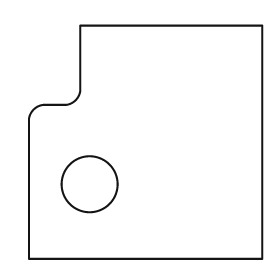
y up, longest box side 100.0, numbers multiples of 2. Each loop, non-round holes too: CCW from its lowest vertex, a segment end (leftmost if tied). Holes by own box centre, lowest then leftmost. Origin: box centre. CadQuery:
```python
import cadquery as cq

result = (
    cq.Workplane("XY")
    .moveTo(-50.0, -50.0)
    .lineTo(50.0, -50.0)
    .lineTo(50.0, 50.0)
    .lineTo(-28.0, 50.0)
    .lineTo(-28.0, 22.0)
    .threePointArc((-30.0, 18.0), (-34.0, 16.0))
    .lineTo(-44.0, 16.0)
    .threePointArc((-48.0, 14.0), (-50.0, 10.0))
    .close()
    .moveTo(-24.0, -18.0)
    .circle(12.0)
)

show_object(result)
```